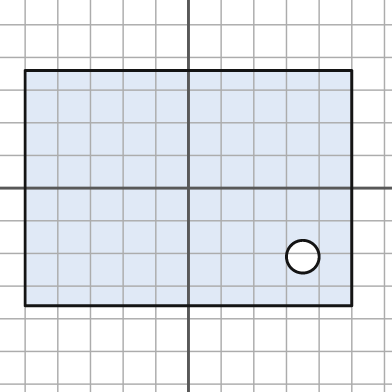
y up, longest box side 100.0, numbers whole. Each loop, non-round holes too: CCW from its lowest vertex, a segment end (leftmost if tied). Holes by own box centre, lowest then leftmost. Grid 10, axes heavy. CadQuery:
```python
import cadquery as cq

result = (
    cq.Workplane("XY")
    .moveTo(-50.0, -36.0)
    .lineTo(50.0, -36.0)
    .lineTo(50.0, 36.0)
    .lineTo(-50.0, 36.0)
    .close()
    .moveTo(35.0, -21.0)
    .circle(5.0)
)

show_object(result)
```